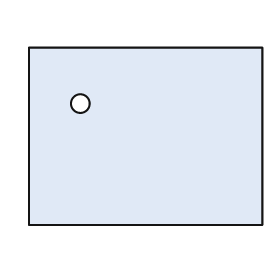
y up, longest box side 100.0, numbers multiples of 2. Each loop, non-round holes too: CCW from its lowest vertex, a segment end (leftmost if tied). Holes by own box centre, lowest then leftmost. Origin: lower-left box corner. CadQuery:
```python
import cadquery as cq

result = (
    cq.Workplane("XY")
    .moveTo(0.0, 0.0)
    .lineTo(100.0, 0.0)
    .lineTo(100.0, 76.0)
    .lineTo(0.0, 76.0)
    .close()
    .moveTo(22.0, 52.0)
    .circle(4.0)
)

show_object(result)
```